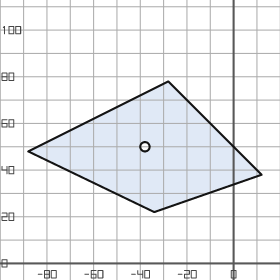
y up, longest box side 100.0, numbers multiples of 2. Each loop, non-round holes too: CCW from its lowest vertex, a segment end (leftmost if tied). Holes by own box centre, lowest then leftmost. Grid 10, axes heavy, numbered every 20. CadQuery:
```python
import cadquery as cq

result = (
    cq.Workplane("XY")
    .moveTo(-34.0, 22.0)
    .lineTo(12.0, 38.0)
    .lineTo(-28.0, 78.0)
    .lineTo(-88.0, 48.0)
    .close()
    .moveTo(-38.0, 50.0)
    .circle(2.0)
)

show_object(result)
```